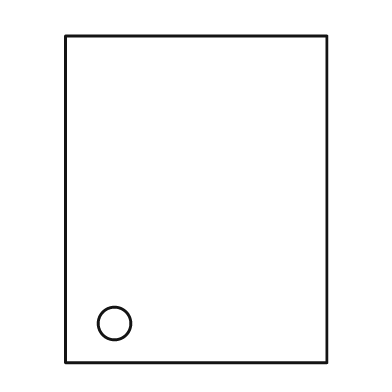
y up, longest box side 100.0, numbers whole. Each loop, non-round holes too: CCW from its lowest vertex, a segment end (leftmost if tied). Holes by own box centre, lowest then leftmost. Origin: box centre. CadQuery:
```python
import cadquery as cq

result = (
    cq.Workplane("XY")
    .moveTo(-40.0, -50.0)
    .lineTo(40.0, -50.0)
    .lineTo(40.0, 50.0)
    .lineTo(-40.0, 50.0)
    .close()
    .moveTo(-25.0, -38.0)
    .circle(5.0)
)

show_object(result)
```